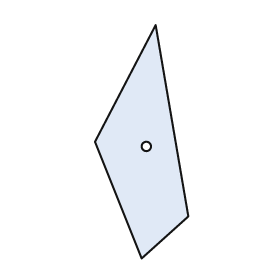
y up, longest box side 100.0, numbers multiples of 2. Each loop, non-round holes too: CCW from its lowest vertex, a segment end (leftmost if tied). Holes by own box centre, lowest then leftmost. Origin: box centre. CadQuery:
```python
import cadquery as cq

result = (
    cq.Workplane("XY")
    .moveTo(0.0, -50.0)
    .lineTo(20.0, -32.0)
    .lineTo(6.0, 50.0)
    .lineTo(-20.0, 0.0)
    .close()
    .moveTo(2.0, -2.0)
    .circle(2.0)
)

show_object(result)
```